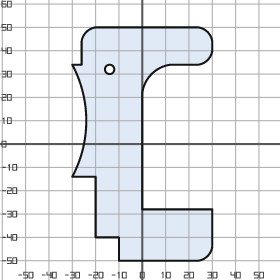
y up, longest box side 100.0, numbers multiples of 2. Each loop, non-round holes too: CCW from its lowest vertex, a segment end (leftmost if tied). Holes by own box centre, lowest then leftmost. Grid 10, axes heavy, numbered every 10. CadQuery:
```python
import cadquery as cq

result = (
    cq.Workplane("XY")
    .moveTo(-10.0, -50.0)
    .lineTo(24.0, -50.0)
    .threePointArc((28.0, -48.0), (30.0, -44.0))
    .lineTo(30.0, -28.0)
    .lineTo(0.0, -28.0)
    .lineTo(0.0, 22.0)
    .threePointArc((4.0, 30.0), (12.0, 34.0))
    .lineTo(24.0, 34.0)
    .threePointArc((28.0, 36.0), (30.0, 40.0))
    .lineTo(30.0, 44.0)
    .threePointArc((28.0, 48.0), (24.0, 50.0))
    .lineTo(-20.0, 50.0)
    .threePointArc((-24.0, 48.0), (-26.0, 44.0))
    .lineTo(-26.0, 34.0)
    .lineTo(-30.0, 34.0)
    .threePointArc((-24.0, 10.0), (-30.0, -14.0))
    .lineTo(-20.0, -14.0)
    .lineTo(-20.0, -40.0)
    .lineTo(-10.0, -40.0)
    .close()
    .moveTo(-14.0, 32.0)
    .circle(2.0)
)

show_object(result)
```